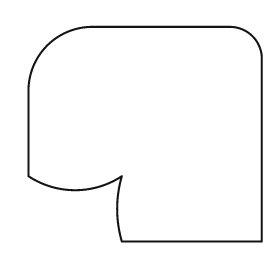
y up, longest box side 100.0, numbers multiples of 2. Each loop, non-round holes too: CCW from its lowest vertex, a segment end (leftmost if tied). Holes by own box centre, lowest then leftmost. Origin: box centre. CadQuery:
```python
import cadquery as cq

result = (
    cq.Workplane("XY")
    .moveTo(-10.0, -46.0)
    .lineTo(50.0, -46.0)
    .lineTo(50.0, 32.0)
    .threePointArc((46.0, 42.0), (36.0, 46.0))
    .lineTo(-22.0, 46.0)
    .threePointArc((-42.0, 38.0), (-50.0, 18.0))
    .lineTo(-50.0, -18.0)
    .threePointArc((-30.0, -24.0), (-10.0, -18.0))
    .threePointArc((-12.0, -32.0), (-10.0, -46.0))
    .close()
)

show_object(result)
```